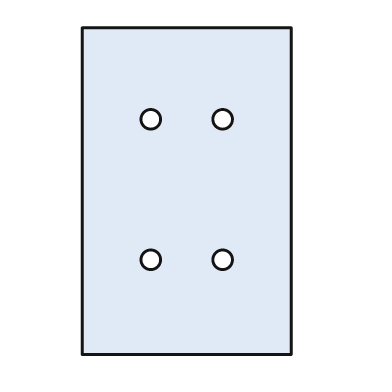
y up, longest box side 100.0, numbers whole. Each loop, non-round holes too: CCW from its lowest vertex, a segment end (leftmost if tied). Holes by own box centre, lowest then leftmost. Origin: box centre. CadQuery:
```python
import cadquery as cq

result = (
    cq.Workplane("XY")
    .moveTo(-32.0, -50.0)
    .lineTo(32.0, -50.0)
    .lineTo(32.0, 50.0)
    .lineTo(-32.0, 50.0)
    .close()
    .moveTo(-11.0, -21.0)
    .circle(3.0)
    .moveTo(11.0, -21.0)
    .circle(3.0)
    .moveTo(-11.0, 22.0)
    .circle(3.0)
    .moveTo(11.0, 22.0)
    .circle(3.0)
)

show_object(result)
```